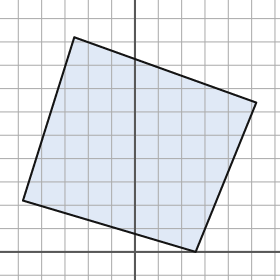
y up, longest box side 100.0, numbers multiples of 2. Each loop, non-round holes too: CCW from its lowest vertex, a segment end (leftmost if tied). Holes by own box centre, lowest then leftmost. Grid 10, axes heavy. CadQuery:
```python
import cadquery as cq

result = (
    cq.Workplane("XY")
    .moveTo(26.0, 0.0)
    .lineTo(52.0, 64.0)
    .lineTo(-26.0, 92.0)
    .lineTo(-48.0, 22.0)
    .close()
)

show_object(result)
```